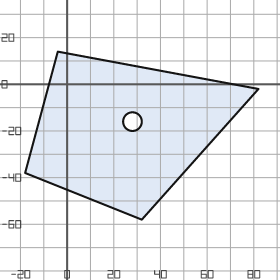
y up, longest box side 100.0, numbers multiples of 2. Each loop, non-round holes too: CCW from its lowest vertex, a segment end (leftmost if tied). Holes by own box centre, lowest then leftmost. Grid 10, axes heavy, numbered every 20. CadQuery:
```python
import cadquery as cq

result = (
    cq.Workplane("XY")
    .moveTo(32.0, -58.0)
    .lineTo(82.0, -2.0)
    .lineTo(-4.0, 14.0)
    .lineTo(-18.0, -38.0)
    .close()
    .moveTo(28.0, -16.0)
    .circle(4.0)
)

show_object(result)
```